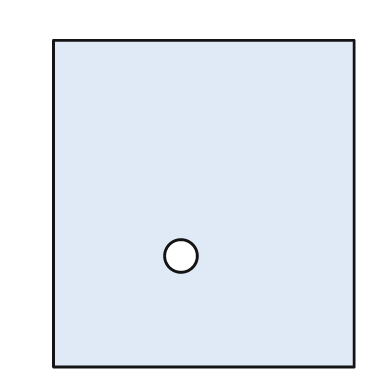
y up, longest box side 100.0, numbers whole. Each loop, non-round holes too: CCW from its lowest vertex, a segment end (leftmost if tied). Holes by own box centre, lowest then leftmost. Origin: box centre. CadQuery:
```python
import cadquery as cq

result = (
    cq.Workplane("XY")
    .moveTo(-46.0, -50.0)
    .lineTo(46.0, -50.0)
    .lineTo(46.0, 50.0)
    .lineTo(-46.0, 50.0)
    .close()
    .moveTo(-7.0, -16.0)
    .circle(5.0)
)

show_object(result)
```